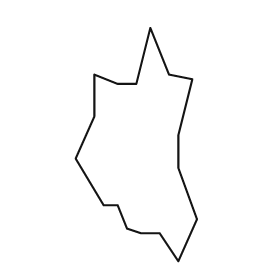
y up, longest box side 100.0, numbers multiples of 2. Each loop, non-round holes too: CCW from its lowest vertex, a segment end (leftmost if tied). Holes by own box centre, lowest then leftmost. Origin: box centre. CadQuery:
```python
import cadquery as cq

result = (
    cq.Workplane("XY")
    .moveTo(18.0, -50.0)
    .lineTo(26.0, -32.0)
    .lineTo(18.0, -10.0)
    .lineTo(18.0, 4.0)
    .lineTo(24.0, 28.0)
    .lineTo(14.0, 30.0)
    .lineTo(6.0, 50.0)
    .lineTo(0.0, 26.0)
    .lineTo(-8.0, 26.0)
    .lineTo(-18.0, 30.0)
    .lineTo(-18.0, 12.0)
    .lineTo(-26.0, -6.0)
    .lineTo(-14.0, -26.0)
    .lineTo(-8.0, -26.0)
    .lineTo(-4.0, -36.0)
    .lineTo(2.0, -38.0)
    .lineTo(10.0, -38.0)
    .close()
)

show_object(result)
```